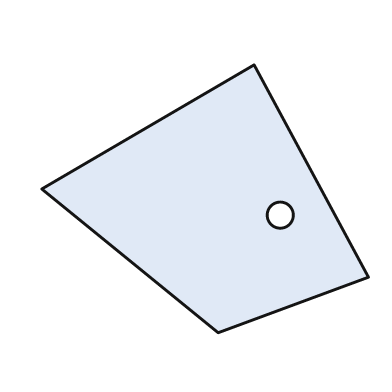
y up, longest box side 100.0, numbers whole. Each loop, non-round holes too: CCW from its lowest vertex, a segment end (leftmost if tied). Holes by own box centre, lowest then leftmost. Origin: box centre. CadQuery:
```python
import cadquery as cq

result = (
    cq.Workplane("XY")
    .moveTo(4.0, -41.0)
    .lineTo(50.0, -24.0)
    .lineTo(15.0, 41.0)
    .lineTo(-50.0, 3.0)
    .close()
    .moveTo(23.0, -5.0)
    .circle(4.0)
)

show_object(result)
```